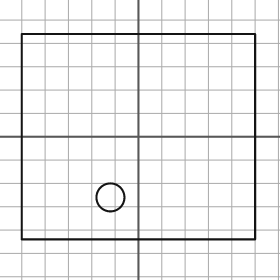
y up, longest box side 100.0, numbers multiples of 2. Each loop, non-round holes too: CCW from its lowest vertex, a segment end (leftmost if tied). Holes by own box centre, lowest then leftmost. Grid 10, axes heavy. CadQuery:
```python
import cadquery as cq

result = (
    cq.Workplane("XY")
    .moveTo(-50.0, -44.0)
    .lineTo(50.0, -44.0)
    .lineTo(50.0, 44.0)
    .lineTo(-50.0, 44.0)
    .close()
    .moveTo(-12.0, -26.0)
    .circle(6.0)
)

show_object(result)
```